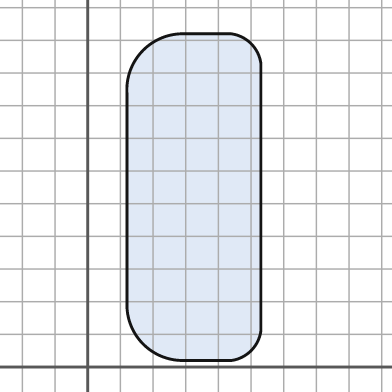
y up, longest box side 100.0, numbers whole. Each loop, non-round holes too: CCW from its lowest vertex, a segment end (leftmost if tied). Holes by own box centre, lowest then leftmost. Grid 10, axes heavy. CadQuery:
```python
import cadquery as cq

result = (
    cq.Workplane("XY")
    .moveTo(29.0, 2.0)
    .lineTo(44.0, 2.0)
    .threePointArc((50.0, 5.0), (53.0, 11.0))
    .lineTo(53.0, 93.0)
    .threePointArc((50.0, 99.0), (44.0, 102.0))
    .lineTo(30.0, 102.0)
    .threePointArc((17.0, 97.0), (12.0, 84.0))
    .lineTo(12.0, 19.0)
    .threePointArc((17.0, 7.0), (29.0, 2.0))
    .close()
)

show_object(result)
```